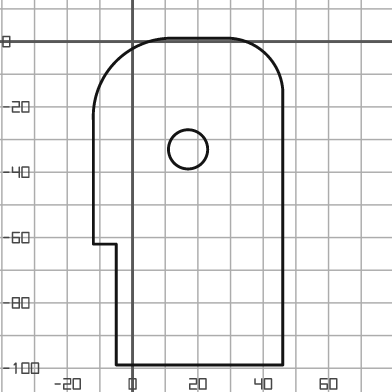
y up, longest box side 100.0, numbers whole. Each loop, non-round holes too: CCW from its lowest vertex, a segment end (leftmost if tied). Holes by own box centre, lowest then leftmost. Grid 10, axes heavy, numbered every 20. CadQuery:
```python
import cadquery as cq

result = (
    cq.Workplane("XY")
    .moveTo(-5.0, -99.0)
    .lineTo(46.0, -99.0)
    .lineTo(46.0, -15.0)
    .threePointArc((41.0, -4.0), (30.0, 1.0))
    .lineTo(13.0, 1.0)
    .threePointArc((-5.0, -6.0), (-12.0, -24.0))
    .lineTo(-12.0, -62.0)
    .lineTo(-5.0, -62.0)
    .close()
    .moveTo(17.0, -33.0)
    .circle(6.0)
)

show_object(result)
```